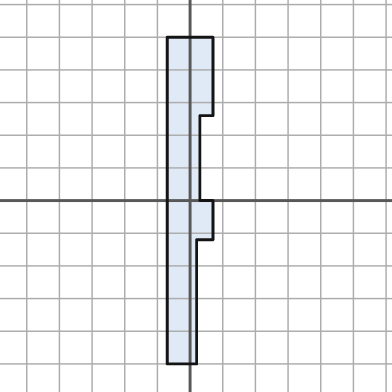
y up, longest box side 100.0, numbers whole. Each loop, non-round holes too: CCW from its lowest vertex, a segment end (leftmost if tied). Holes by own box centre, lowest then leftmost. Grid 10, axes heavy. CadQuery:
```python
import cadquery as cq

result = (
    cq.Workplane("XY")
    .moveTo(-7.0, -50.0)
    .lineTo(2.0, -50.0)
    .lineTo(2.0, -12.0)
    .lineTo(7.0, -12.0)
    .lineTo(7.0, 0.0)
    .lineTo(3.0, 0.0)
    .lineTo(3.0, 26.0)
    .lineTo(7.0, 26.0)
    .lineTo(7.0, 50.0)
    .lineTo(-7.0, 50.0)
    .close()
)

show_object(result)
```